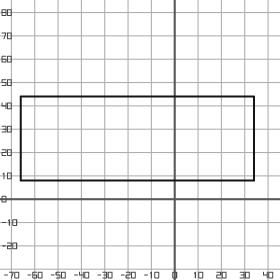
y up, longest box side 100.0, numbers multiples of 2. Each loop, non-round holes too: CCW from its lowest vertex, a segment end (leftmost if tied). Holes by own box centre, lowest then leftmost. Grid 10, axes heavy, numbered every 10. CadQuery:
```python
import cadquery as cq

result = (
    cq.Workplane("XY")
    .moveTo(-66.0, 8.0)
    .lineTo(34.0, 8.0)
    .lineTo(34.0, 44.0)
    .lineTo(-66.0, 44.0)
    .close()
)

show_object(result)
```